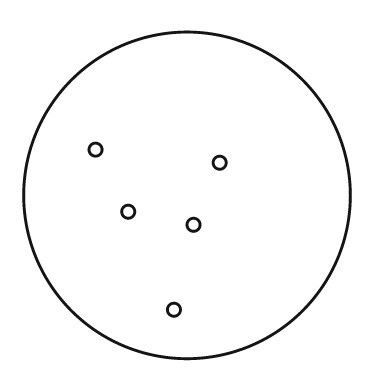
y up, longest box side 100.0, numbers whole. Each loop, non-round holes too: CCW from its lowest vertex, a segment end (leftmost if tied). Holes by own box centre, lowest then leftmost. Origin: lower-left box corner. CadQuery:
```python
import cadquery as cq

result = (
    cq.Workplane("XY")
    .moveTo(50.0, 50.0)
    .circle(50.0)
    .moveTo(46.0, 15.0)
    .circle(2.0)
    .moveTo(52.0, 41.0)
    .circle(2.0)
    .moveTo(32.0, 45.0)
    .circle(2.0)
    .moveTo(60.0, 60.0)
    .circle(2.0)
    .moveTo(22.0, 64.0)
    .circle(2.0)
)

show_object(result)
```